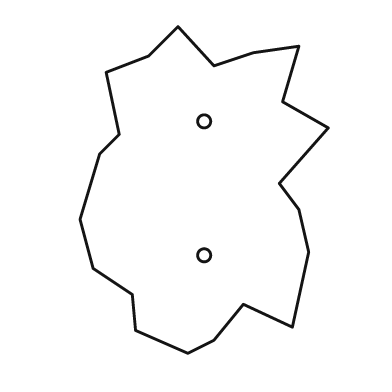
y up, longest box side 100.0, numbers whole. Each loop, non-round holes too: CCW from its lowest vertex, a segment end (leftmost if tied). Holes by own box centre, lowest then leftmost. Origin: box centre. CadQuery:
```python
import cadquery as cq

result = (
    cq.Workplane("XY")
    .moveTo(-5.0, -50.0)
    .lineTo(3.0, -46.0)
    .lineTo(12.0, -35.0)
    .lineTo(27.0, -42.0)
    .lineTo(32.0, -19.0)
    .lineTo(29.0, -6.0)
    .lineTo(23.0, 2.0)
    .lineTo(38.0, 19.0)
    .lineTo(24.0, 27.0)
    .lineTo(29.0, 44.0)
    .lineTo(15.0, 42.0)
    .lineTo(3.0, 38.0)
    .lineTo(-8.0, 50.0)
    .lineTo(-17.0, 41.0)
    .lineTo(-30.0, 36.0)
    .lineTo(-26.0, 17.0)
    .lineTo(-32.0, 11.0)
    .lineTo(-38.0, -9.0)
    .lineTo(-34.0, -24.0)
    .lineTo(-22.0, -32.0)
    .lineTo(-21.0, -43.0)
    .close()
    .moveTo(0.0, -20.0)
    .circle(2.0)
    .moveTo(0.0, 21.0)
    .circle(2.0)
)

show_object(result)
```